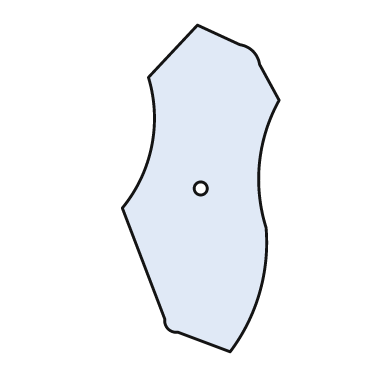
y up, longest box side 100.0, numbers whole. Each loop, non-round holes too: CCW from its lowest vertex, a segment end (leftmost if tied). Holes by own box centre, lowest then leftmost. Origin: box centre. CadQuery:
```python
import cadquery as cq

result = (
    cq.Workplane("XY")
    .moveTo(9.0, -50.0)
    .threePointArc((18.0, -32.0), (20.0, -12.0))
    .threePointArc((18.0, 8.0), (24.0, 27.0))
    .lineTo(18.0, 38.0)
    .threePointArc((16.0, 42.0), (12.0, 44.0))
    .lineTo(-1.0, 50.0)
    .lineTo(-16.0, 34.0)
    .threePointArc((-15.0, 13.0), (-24.0, -6.0))
    .lineTo(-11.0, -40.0)
    .threePointArc((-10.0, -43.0), (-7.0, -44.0))
    .close()
    .moveTo(0.0, 0.0)
    .circle(2.0)
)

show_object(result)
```